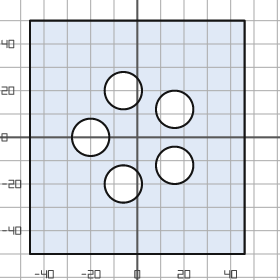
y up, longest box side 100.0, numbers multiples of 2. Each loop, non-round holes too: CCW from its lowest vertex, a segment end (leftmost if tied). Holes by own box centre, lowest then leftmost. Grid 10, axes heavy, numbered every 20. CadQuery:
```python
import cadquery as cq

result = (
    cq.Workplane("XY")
    .moveTo(-46.0, -50.0)
    .lineTo(46.0, -50.0)
    .lineTo(46.0, 50.0)
    .lineTo(-46.0, 50.0)
    .close()
    .moveTo(-6.0, -20.0)
    .circle(8.0)
    .moveTo(16.0, -12.0)
    .circle(8.0)
    .moveTo(-20.0, 0.0)
    .circle(8.0)
    .moveTo(16.0, 12.0)
    .circle(8.0)
    .moveTo(-6.0, 20.0)
    .circle(8.0)
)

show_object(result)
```